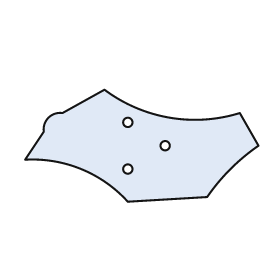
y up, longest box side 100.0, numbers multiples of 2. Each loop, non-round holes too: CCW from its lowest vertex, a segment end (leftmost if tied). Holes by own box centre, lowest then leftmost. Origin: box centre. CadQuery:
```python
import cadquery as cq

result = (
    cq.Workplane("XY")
    .moveTo(-6.0, -24.0)
    .lineTo(28.0, -22.0)
    .threePointArc((38.0, -10.0), (50.0, 0.0))
    .lineTo(42.0, 14.0)
    .threePointArc((12.0, 12.0), (-16.0, 24.0))
    .lineTo(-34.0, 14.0)
    .threePointArc((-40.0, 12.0), (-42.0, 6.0))
    .lineTo(-50.0, -6.0)
    .threePointArc((-26.0, -10.0), (-6.0, -24.0))
    .close()
    .moveTo(-6.0, -10.0)
    .circle(2.0)
    .moveTo(10.0, 0.0)
    .circle(2.0)
    .moveTo(-6.0, 10.0)
    .circle(2.0)
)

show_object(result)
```